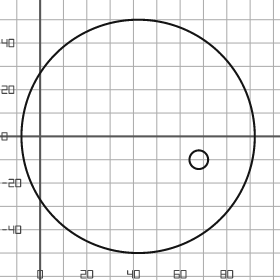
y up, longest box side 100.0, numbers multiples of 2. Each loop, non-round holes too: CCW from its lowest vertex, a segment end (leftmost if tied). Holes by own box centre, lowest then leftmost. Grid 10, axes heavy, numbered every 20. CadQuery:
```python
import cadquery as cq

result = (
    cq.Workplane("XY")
    .moveTo(42.0, 0.0)
    .circle(50.0)
    .moveTo(68.0, -10.0)
    .circle(4.0)
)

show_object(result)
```